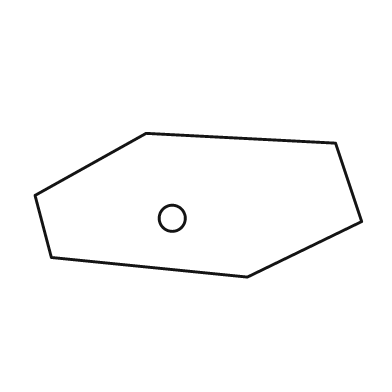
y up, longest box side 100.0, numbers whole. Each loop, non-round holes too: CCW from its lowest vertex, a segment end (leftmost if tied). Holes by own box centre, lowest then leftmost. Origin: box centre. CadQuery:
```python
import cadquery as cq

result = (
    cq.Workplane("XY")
    .moveTo(15.0, -22.0)
    .lineTo(50.0, -5.0)
    .lineTo(42.0, 19.0)
    .lineTo(-16.0, 22.0)
    .lineTo(-50.0, 3.0)
    .lineTo(-45.0, -16.0)
    .close()
    .moveTo(-8.0, -4.0)
    .circle(4.0)
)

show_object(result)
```